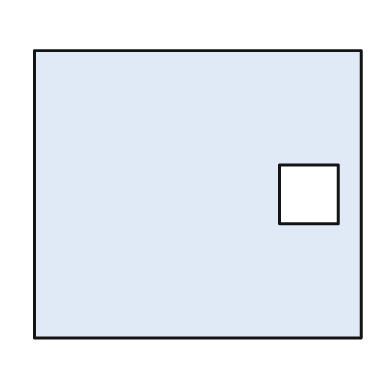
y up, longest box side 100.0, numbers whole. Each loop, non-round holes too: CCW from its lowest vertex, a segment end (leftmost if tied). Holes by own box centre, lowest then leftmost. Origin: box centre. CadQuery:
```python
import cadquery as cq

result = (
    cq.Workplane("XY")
    .moveTo(-50.0, -44.0)
    .lineTo(50.0, -44.0)
    .lineTo(50.0, 44.0)
    .lineTo(-50.0, 44.0)
    .close()
    .moveTo(25.0, -9.0)
    .lineTo(43.0, -9.0)
    .lineTo(43.0, 9.0)
    .lineTo(25.0, 9.0)
    .close()
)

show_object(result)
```